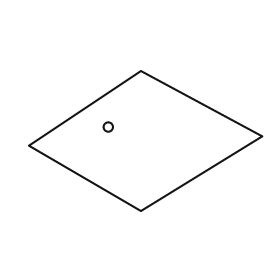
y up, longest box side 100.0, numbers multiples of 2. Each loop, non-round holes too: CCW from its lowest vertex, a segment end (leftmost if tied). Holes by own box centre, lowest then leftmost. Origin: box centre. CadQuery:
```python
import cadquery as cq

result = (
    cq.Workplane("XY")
    .moveTo(-2.0, -30.0)
    .lineTo(50.0, 2.0)
    .lineTo(-2.0, 30.0)
    .lineTo(-50.0, -2.0)
    .close()
    .moveTo(-16.0, 6.0)
    .circle(2.0)
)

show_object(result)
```